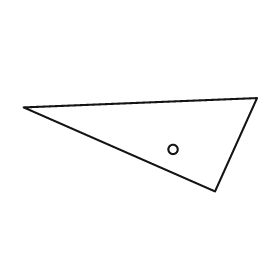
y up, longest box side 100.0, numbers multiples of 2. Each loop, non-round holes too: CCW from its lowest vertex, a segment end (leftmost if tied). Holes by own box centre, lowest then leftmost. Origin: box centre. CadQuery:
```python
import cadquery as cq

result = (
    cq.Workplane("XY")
    .moveTo(32.0, -20.0)
    .lineTo(50.0, 20.0)
    .lineTo(-50.0, 16.0)
    .close()
    .moveTo(14.0, -2.0)
    .circle(2.0)
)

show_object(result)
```